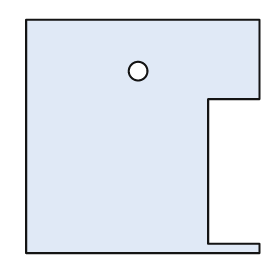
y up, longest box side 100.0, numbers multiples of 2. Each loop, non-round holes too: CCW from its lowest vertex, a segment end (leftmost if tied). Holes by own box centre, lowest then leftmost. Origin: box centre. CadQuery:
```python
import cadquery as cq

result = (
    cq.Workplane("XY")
    .moveTo(-50.0, -50.0)
    .lineTo(50.0, -50.0)
    .lineTo(50.0, -46.0)
    .lineTo(28.0, -46.0)
    .lineTo(28.0, 16.0)
    .lineTo(50.0, 16.0)
    .lineTo(50.0, 50.0)
    .lineTo(-50.0, 50.0)
    .close()
    .moveTo(-2.0, 28.0)
    .circle(4.0)
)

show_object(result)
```